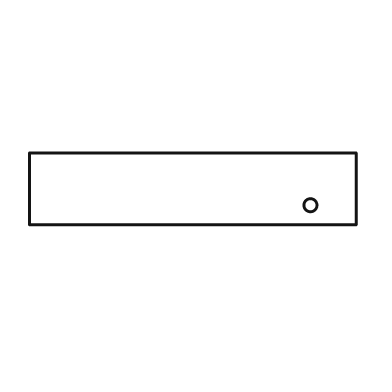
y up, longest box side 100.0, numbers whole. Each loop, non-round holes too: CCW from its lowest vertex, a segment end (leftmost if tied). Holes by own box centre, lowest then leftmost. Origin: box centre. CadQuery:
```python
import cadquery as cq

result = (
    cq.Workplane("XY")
    .moveTo(-50.0, -11.0)
    .lineTo(50.0, -11.0)
    .lineTo(50.0, 11.0)
    .lineTo(-50.0, 11.0)
    .close()
    .moveTo(36.0, -5.0)
    .circle(2.0)
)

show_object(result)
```